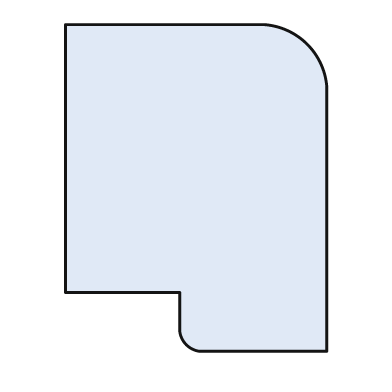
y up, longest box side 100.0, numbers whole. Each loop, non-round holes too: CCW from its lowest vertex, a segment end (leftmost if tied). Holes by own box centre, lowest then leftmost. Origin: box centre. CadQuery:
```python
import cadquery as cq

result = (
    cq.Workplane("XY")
    .moveTo(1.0, -50.0)
    .lineTo(40.0, -50.0)
    .lineTo(40.0, 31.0)
    .threePointArc((34.0, 44.0), (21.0, 50.0))
    .lineTo(-40.0, 50.0)
    .lineTo(-40.0, -32.0)
    .lineTo(-5.0, -32.0)
    .lineTo(-5.0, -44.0)
    .threePointArc((-3.0, -48.0), (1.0, -50.0))
    .close()
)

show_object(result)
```